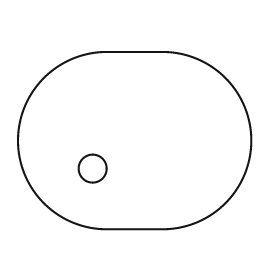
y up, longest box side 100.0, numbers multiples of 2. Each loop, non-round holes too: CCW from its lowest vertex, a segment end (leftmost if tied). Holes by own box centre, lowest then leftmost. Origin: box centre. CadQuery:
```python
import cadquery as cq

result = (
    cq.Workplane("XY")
    .moveTo(-12.0, -38.0)
    .lineTo(12.0, -38.0)
    .threePointArc((50.0, 0.0), (12.0, 38.0))
    .lineTo(-12.0, 38.0)
    .threePointArc((-50.0, 0.0), (-12.0, -38.0))
    .close()
    .moveTo(-18.0, -12.0)
    .circle(6.0)
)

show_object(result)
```